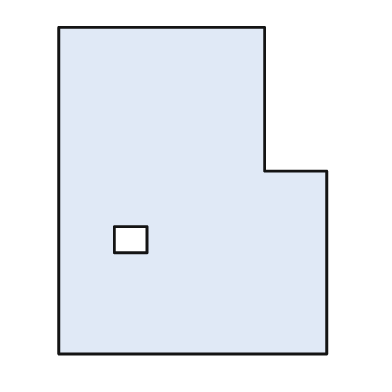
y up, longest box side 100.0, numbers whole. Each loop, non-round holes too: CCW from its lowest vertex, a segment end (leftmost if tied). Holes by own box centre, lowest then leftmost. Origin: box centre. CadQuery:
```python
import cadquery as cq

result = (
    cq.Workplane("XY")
    .moveTo(-41.0, -50.0)
    .lineTo(41.0, -50.0)
    .lineTo(41.0, 6.0)
    .lineTo(22.0, 6.0)
    .lineTo(22.0, 50.0)
    .lineTo(-41.0, 50.0)
    .close()
    .moveTo(-24.0, -19.0)
    .lineTo(-14.0, -19.0)
    .lineTo(-14.0, -11.0)
    .lineTo(-24.0, -11.0)
    .close()
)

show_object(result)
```